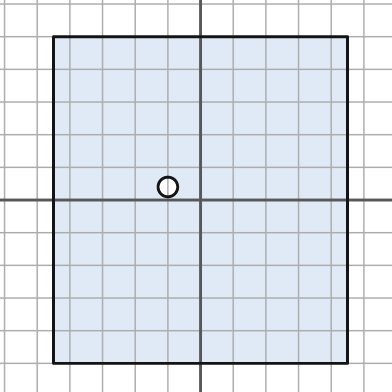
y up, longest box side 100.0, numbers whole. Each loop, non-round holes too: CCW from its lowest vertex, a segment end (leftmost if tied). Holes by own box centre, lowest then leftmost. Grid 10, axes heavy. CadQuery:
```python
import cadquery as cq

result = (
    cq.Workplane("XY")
    .moveTo(-45.0, -50.0)
    .lineTo(45.0, -50.0)
    .lineTo(45.0, 50.0)
    .lineTo(-45.0, 50.0)
    .close()
    .moveTo(-10.0, 4.0)
    .circle(3.0)
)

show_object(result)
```